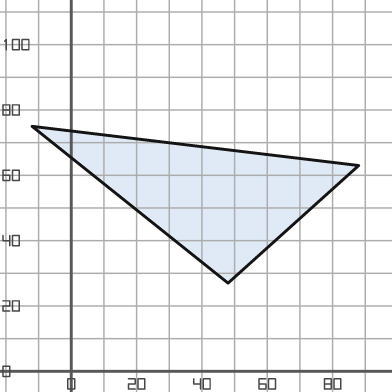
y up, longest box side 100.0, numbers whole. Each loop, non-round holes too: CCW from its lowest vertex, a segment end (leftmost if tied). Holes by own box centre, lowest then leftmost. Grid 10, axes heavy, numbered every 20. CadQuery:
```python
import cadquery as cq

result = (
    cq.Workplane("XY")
    .moveTo(48.0, 27.0)
    .lineTo(88.0, 63.0)
    .lineTo(-12.0, 75.0)
    .close()
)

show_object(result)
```